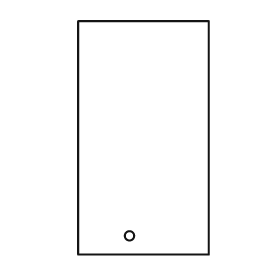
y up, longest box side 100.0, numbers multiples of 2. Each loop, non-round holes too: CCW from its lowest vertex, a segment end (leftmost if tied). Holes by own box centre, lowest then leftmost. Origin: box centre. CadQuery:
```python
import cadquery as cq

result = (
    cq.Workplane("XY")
    .moveTo(-28.0, -50.0)
    .lineTo(28.0, -50.0)
    .lineTo(28.0, 50.0)
    .lineTo(-28.0, 50.0)
    .close()
    .moveTo(-6.0, -42.0)
    .circle(2.0)
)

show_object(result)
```